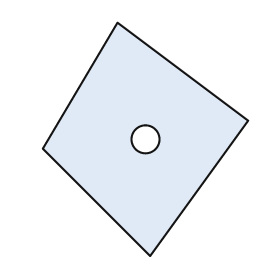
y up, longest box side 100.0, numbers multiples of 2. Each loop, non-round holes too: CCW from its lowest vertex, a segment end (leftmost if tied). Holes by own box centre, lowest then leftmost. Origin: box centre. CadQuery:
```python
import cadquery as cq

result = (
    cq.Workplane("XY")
    .moveTo(2.0, -50.0)
    .lineTo(44.0, 8.0)
    .lineTo(-12.0, 50.0)
    .lineTo(-44.0, -4.0)
    .close()
    .moveTo(0.0, 0.0)
    .circle(6.0)
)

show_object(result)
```